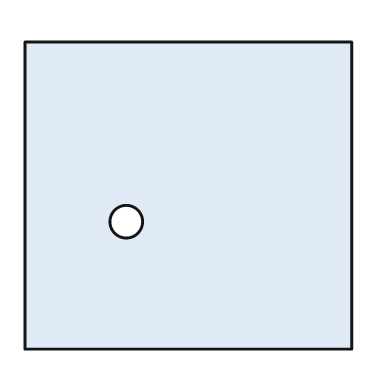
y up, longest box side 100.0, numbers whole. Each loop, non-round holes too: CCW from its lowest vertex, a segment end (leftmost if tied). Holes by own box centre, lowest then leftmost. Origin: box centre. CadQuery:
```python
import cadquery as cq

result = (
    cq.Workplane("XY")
    .moveTo(-50.0, -47.0)
    .lineTo(50.0, -47.0)
    .lineTo(50.0, 47.0)
    .lineTo(-50.0, 47.0)
    .close()
    .moveTo(-19.0, -8.0)
    .circle(5.0)
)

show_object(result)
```